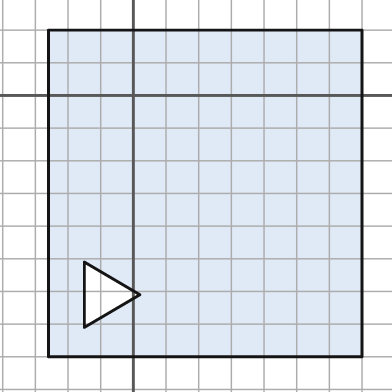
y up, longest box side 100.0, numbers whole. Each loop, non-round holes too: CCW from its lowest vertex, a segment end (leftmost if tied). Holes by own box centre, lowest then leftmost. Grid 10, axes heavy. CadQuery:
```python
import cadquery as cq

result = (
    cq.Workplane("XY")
    .moveTo(-26.0, -80.0)
    .lineTo(70.0, -80.0)
    .lineTo(70.0, 20.0)
    .lineTo(-26.0, 20.0)
    .close()
    .moveTo(-15.0, -71.0)
    .lineTo(2.0, -61.0)
    .lineTo(-15.0, -51.0)
    .close()
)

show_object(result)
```